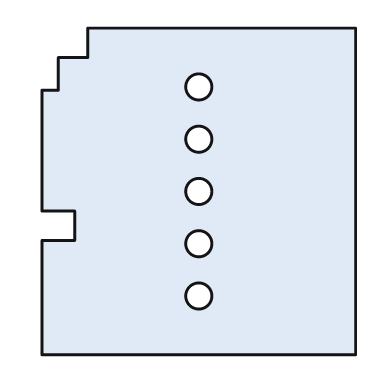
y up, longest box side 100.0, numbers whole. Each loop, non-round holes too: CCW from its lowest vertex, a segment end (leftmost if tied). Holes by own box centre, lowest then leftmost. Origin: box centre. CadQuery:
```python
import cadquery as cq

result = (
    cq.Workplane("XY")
    .moveTo(-48.0, -50.0)
    .lineTo(48.0, -50.0)
    .lineTo(48.0, 50.0)
    .lineTo(-34.0, 50.0)
    .lineTo(-34.0, 41.0)
    .lineTo(-43.0, 41.0)
    .lineTo(-43.0, 31.0)
    .lineTo(-48.0, 31.0)
    .lineTo(-48.0, -6.0)
    .lineTo(-38.0, -6.0)
    .lineTo(-38.0, -15.0)
    .lineTo(-48.0, -15.0)
    .close()
    .moveTo(0.0, -32.0)
    .circle(4.0)
    .moveTo(0.0, -16.0)
    .circle(4.0)
    .moveTo(0.0, 0.0)
    .circle(4.0)
    .moveTo(0.0, 16.0)
    .circle(4.0)
    .moveTo(0.0, 32.0)
    .circle(4.0)
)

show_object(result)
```